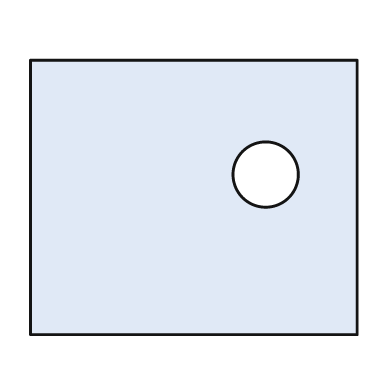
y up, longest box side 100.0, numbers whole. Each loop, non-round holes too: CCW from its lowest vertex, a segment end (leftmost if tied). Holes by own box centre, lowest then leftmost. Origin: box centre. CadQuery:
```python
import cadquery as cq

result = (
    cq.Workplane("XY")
    .moveTo(-50.0, -42.0)
    .lineTo(50.0, -42.0)
    .lineTo(50.0, 42.0)
    .lineTo(-50.0, 42.0)
    .close()
    .moveTo(22.0, 7.0)
    .circle(10.0)
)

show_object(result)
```